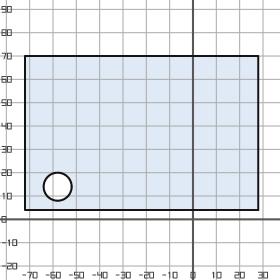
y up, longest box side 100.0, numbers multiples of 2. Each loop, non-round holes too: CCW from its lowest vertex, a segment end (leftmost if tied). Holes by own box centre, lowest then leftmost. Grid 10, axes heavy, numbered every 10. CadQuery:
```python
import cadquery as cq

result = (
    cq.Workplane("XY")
    .moveTo(-72.0, 4.0)
    .lineTo(28.0, 4.0)
    .lineTo(28.0, 70.0)
    .lineTo(-72.0, 70.0)
    .close()
    .moveTo(-58.0, 14.0)
    .circle(6.0)
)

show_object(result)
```